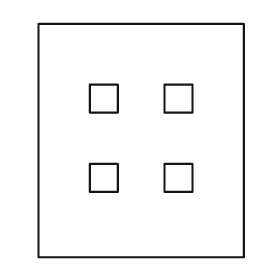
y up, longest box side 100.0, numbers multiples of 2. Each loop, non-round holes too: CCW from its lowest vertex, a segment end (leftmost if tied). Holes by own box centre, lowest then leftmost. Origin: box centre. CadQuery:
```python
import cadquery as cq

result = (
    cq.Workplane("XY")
    .moveTo(-44.0, -50.0)
    .lineTo(44.0, -50.0)
    .lineTo(44.0, 50.0)
    .lineTo(-44.0, 50.0)
    .close()
    .moveTo(-22.0, -22.0)
    .lineTo(-10.0, -22.0)
    .lineTo(-10.0, -10.0)
    .lineTo(-22.0, -10.0)
    .close()
    .moveTo(10.0, -22.0)
    .lineTo(22.0, -22.0)
    .lineTo(22.0, -10.0)
    .lineTo(10.0, -10.0)
    .close()
    .moveTo(-22.0, 12.0)
    .lineTo(-10.0, 12.0)
    .lineTo(-10.0, 24.0)
    .lineTo(-22.0, 24.0)
    .close()
    .moveTo(10.0, 12.0)
    .lineTo(22.0, 12.0)
    .lineTo(22.0, 24.0)
    .lineTo(10.0, 24.0)
    .close()
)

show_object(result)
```